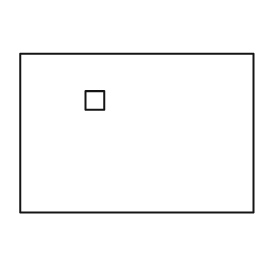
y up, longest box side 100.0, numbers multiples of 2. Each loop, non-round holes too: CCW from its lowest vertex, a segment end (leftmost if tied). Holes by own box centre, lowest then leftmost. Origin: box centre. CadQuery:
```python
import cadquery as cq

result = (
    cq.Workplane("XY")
    .moveTo(-50.0, -34.0)
    .lineTo(50.0, -34.0)
    .lineTo(50.0, 34.0)
    .lineTo(-50.0, 34.0)
    .close()
    .moveTo(-22.0, 10.0)
    .lineTo(-14.0, 10.0)
    .lineTo(-14.0, 18.0)
    .lineTo(-22.0, 18.0)
    .close()
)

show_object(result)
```